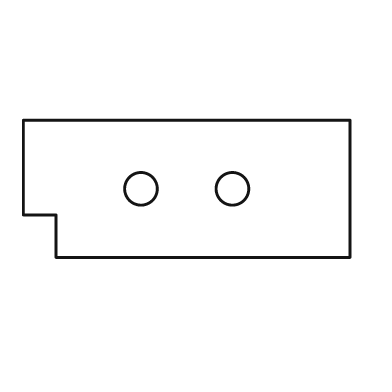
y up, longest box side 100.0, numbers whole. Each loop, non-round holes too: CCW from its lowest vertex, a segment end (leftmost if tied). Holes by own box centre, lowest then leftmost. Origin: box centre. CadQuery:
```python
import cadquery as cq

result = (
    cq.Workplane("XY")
    .moveTo(-40.0, -21.0)
    .lineTo(50.0, -21.0)
    .lineTo(50.0, 21.0)
    .lineTo(-50.0, 21.0)
    .lineTo(-50.0, -8.0)
    .lineTo(-40.0, -8.0)
    .close()
    .moveTo(-14.0, 0.0)
    .circle(5.0)
    .moveTo(14.0, 0.0)
    .circle(5.0)
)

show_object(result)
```